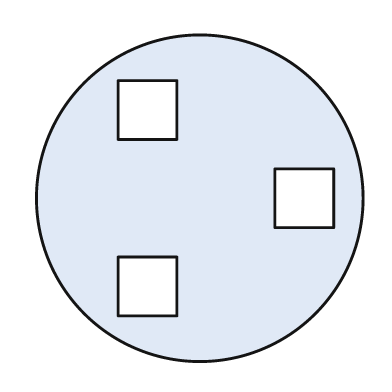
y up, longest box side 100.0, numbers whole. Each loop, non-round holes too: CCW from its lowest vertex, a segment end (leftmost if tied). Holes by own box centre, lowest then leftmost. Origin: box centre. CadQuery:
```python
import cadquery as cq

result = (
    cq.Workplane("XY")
    .moveTo(0.0, 0.0)
    .circle(50.0)
    .moveTo(-25.0, -36.0)
    .lineTo(-7.0, -36.0)
    .lineTo(-7.0, -18.0)
    .lineTo(-25.0, -18.0)
    .close()
    .moveTo(23.0, -9.0)
    .lineTo(41.0, -9.0)
    .lineTo(41.0, 9.0)
    .lineTo(23.0, 9.0)
    .close()
    .moveTo(-25.0, 18.0)
    .lineTo(-7.0, 18.0)
    .lineTo(-7.0, 36.0)
    .lineTo(-25.0, 36.0)
    .close()
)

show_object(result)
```